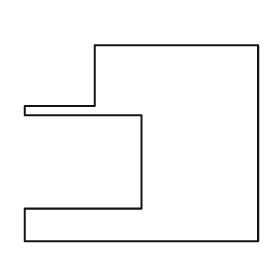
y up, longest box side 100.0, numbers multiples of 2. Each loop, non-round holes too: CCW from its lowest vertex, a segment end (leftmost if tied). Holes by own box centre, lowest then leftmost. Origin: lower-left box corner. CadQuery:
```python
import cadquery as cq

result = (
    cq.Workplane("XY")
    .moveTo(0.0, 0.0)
    .lineTo(100.0, 0.0)
    .lineTo(100.0, 84.0)
    .lineTo(30.0, 84.0)
    .lineTo(30.0, 58.0)
    .lineTo(0.0, 58.0)
    .lineTo(0.0, 54.0)
    .lineTo(50.0, 54.0)
    .lineTo(50.0, 14.0)
    .lineTo(0.0, 14.0)
    .close()
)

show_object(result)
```